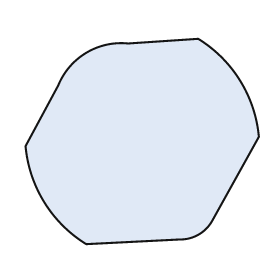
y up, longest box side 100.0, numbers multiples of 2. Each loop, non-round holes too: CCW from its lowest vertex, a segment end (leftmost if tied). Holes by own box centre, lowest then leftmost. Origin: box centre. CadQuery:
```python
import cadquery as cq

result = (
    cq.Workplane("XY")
    .moveTo(-24.0, -44.0)
    .lineTo(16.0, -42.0)
    .threePointArc((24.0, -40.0), (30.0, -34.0))
    .lineTo(50.0, 2.0)
    .threePointArc((42.0, 26.0), (24.0, 44.0))
    .lineTo(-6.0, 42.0)
    .threePointArc((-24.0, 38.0), (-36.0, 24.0))
    .lineTo(-50.0, -2.0)
    .threePointArc((-42.0, -26.0), (-24.0, -44.0))
    .close()
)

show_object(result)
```